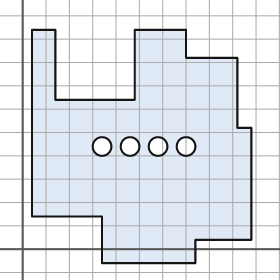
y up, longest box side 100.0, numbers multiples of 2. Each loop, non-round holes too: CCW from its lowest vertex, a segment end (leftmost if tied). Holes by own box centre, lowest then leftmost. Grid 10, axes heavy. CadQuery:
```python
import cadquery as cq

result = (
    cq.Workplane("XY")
    .moveTo(34.0, -6.0)
    .lineTo(74.0, -6.0)
    .lineTo(74.0, 4.0)
    .lineTo(98.0, 4.0)
    .lineTo(98.0, 52.0)
    .lineTo(92.0, 52.0)
    .lineTo(92.0, 82.0)
    .lineTo(70.0, 82.0)
    .lineTo(70.0, 94.0)
    .lineTo(48.0, 94.0)
    .lineTo(48.0, 64.0)
    .lineTo(14.0, 64.0)
    .lineTo(14.0, 94.0)
    .lineTo(4.0, 94.0)
    .lineTo(4.0, 14.0)
    .lineTo(34.0, 14.0)
    .close()
    .moveTo(34.0, 44.0)
    .circle(4.0)
    .moveTo(46.0, 44.0)
    .circle(4.0)
    .moveTo(58.0, 44.0)
    .circle(4.0)
    .moveTo(70.0, 44.0)
    .circle(4.0)
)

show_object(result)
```